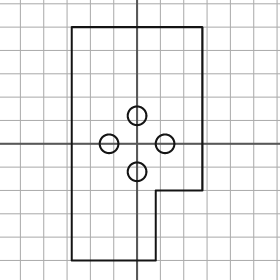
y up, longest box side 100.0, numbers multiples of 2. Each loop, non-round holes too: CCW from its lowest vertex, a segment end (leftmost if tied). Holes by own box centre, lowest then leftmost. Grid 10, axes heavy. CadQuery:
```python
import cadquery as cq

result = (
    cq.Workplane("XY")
    .moveTo(-28.0, -50.0)
    .lineTo(8.0, -50.0)
    .lineTo(8.0, -20.0)
    .lineTo(28.0, -20.0)
    .lineTo(28.0, 50.0)
    .lineTo(-28.0, 50.0)
    .close()
    .moveTo(0.0, -12.0)
    .circle(4.0)
    .moveTo(-12.0, 0.0)
    .circle(4.0)
    .moveTo(12.0, 0.0)
    .circle(4.0)
    .moveTo(0.0, 12.0)
    .circle(4.0)
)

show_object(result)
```